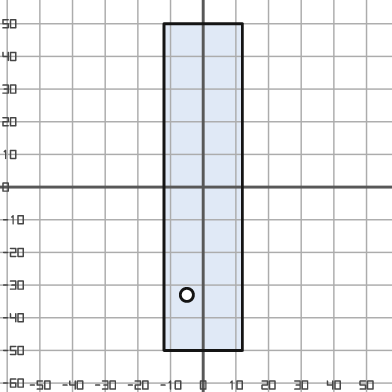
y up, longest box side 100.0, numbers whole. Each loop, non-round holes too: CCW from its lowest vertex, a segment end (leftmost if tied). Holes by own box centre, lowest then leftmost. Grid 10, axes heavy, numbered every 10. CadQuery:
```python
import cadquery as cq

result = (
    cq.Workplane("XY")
    .moveTo(-12.0, -50.0)
    .lineTo(12.0, -50.0)
    .lineTo(12.0, 50.0)
    .lineTo(-12.0, 50.0)
    .close()
    .moveTo(-5.0, -33.0)
    .circle(2.0)
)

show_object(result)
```